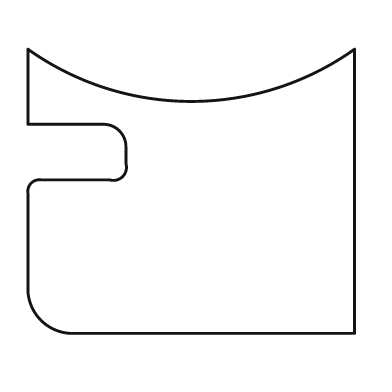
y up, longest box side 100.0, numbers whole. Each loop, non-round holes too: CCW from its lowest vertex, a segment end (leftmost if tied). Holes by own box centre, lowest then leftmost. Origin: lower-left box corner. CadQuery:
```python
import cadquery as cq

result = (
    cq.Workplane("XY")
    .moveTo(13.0, 0.0)
    .lineTo(100.0, 0.0)
    .lineTo(100.0, 87.0)
    .threePointArc((50.0, 71.0), (0.0, 87.0))
    .lineTo(0.0, 64.0)
    .lineTo(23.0, 64.0)
    .threePointArc((28.0, 62.0), (30.0, 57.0))
    .lineTo(30.0, 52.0)
    .threePointArc((29.0, 48.0), (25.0, 47.0))
    .lineTo(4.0, 47.0)
    .threePointArc((1.0, 46.0), (0.0, 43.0))
    .lineTo(0.0, 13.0)
    .threePointArc((4.0, 4.0), (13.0, 0.0))
    .close()
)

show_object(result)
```